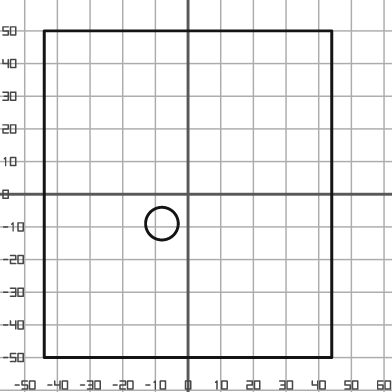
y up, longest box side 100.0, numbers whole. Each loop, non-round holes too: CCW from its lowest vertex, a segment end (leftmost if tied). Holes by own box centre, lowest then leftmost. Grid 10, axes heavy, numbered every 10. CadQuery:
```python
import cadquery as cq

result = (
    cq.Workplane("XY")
    .moveTo(-44.0, -50.0)
    .lineTo(44.0, -50.0)
    .lineTo(44.0, 50.0)
    .lineTo(-44.0, 50.0)
    .close()
    .moveTo(-8.0, -9.0)
    .circle(5.0)
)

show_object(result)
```